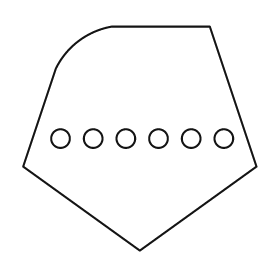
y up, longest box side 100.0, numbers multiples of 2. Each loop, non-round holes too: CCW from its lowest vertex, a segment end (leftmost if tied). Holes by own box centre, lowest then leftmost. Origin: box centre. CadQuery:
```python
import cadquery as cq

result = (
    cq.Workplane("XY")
    .moveTo(0.0, -48.0)
    .lineTo(50.0, -12.0)
    .lineTo(30.0, 48.0)
    .lineTo(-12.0, 48.0)
    .threePointArc((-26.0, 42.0), (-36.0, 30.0))
    .lineTo(-50.0, -12.0)
    .close()
    .moveTo(-34.0, 0.0)
    .circle(4.0)
    .moveTo(-20.0, 0.0)
    .circle(4.0)
    .moveTo(-6.0, 0.0)
    .circle(4.0)
    .moveTo(8.0, 0.0)
    .circle(4.0)
    .moveTo(22.0, 0.0)
    .circle(4.0)
    .moveTo(36.0, 0.0)
    .circle(4.0)
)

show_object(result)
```